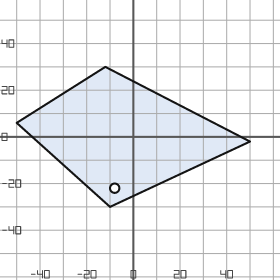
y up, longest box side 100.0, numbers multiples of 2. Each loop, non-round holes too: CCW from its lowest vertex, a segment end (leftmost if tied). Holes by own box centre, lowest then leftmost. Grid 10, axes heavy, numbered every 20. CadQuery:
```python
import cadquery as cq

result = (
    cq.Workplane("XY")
    .moveTo(-10.0, -30.0)
    .lineTo(50.0, -2.0)
    .lineTo(-12.0, 30.0)
    .lineTo(-50.0, 6.0)
    .close()
    .moveTo(-8.0, -22.0)
    .circle(2.0)
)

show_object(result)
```